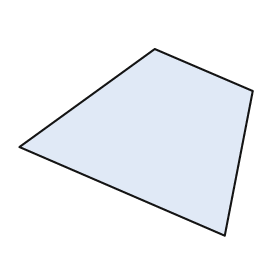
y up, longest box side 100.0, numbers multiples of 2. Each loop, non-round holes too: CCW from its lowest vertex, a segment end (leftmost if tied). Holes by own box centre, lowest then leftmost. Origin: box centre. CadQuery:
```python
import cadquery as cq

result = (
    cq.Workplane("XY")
    .moveTo(38.0, -40.0)
    .lineTo(50.0, 22.0)
    .lineTo(8.0, 40.0)
    .lineTo(-50.0, -2.0)
    .close()
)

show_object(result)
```